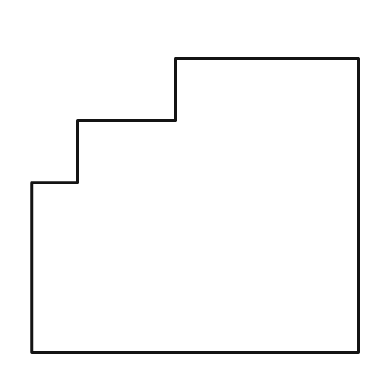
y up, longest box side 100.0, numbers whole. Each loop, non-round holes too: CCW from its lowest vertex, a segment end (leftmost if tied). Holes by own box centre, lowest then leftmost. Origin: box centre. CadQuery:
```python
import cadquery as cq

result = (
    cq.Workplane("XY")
    .moveTo(-50.0, -45.0)
    .lineTo(50.0, -45.0)
    .lineTo(50.0, 45.0)
    .lineTo(-6.0, 45.0)
    .lineTo(-6.0, 26.0)
    .lineTo(-36.0, 26.0)
    .lineTo(-36.0, 7.0)
    .lineTo(-50.0, 7.0)
    .close()
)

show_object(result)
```